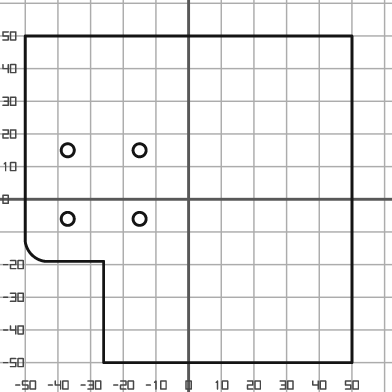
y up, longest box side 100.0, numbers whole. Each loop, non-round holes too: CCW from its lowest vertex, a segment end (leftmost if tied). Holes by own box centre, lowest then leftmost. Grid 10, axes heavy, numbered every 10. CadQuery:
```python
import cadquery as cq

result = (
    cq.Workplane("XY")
    .moveTo(-26.0, -50.0)
    .lineTo(50.0, -50.0)
    .lineTo(50.0, 50.0)
    .lineTo(-50.0, 50.0)
    .lineTo(-50.0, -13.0)
    .threePointArc((-48.0, -17.0), (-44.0, -19.0))
    .lineTo(-26.0, -19.0)
    .close()
    .moveTo(-37.0, -6.0)
    .circle(2.0)
    .moveTo(-15.0, -6.0)
    .circle(2.0)
    .moveTo(-37.0, 15.0)
    .circle(2.0)
    .moveTo(-15.0, 15.0)
    .circle(2.0)
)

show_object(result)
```